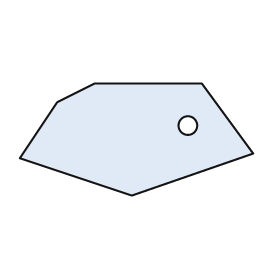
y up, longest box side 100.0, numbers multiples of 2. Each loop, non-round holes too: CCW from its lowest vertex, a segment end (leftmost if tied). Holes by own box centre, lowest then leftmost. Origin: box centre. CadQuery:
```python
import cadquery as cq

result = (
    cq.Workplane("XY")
    .moveTo(-2.0, -24.0)
    .lineTo(50.0, -6.0)
    .lineTo(28.0, 24.0)
    .lineTo(-18.0, 24.0)
    .lineTo(-34.0, 16.0)
    .lineTo(-50.0, -8.0)
    .close()
    .moveTo(22.0, 6.0)
    .circle(4.0)
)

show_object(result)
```